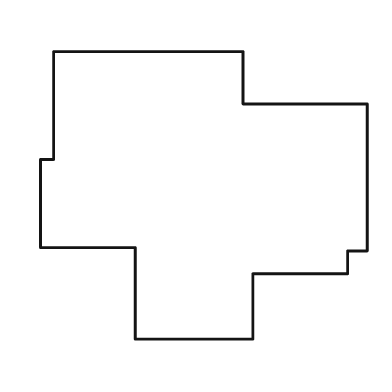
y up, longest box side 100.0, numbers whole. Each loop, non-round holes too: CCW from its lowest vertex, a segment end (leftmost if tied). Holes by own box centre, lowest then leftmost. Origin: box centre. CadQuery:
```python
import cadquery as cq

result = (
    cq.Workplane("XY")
    .moveTo(-21.0, -44.0)
    .lineTo(15.0, -44.0)
    .lineTo(15.0, -24.0)
    .lineTo(44.0, -24.0)
    .lineTo(44.0, -17.0)
    .lineTo(50.0, -17.0)
    .lineTo(50.0, 28.0)
    .lineTo(12.0, 28.0)
    .lineTo(12.0, 44.0)
    .lineTo(-46.0, 44.0)
    .lineTo(-46.0, 11.0)
    .lineTo(-50.0, 11.0)
    .lineTo(-50.0, -16.0)
    .lineTo(-21.0, -16.0)
    .close()
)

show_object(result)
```